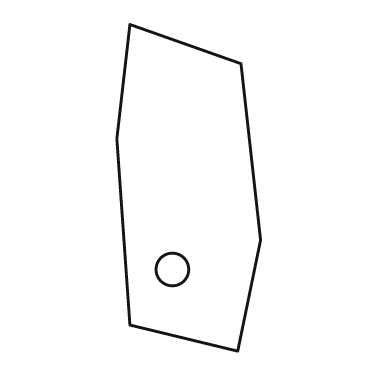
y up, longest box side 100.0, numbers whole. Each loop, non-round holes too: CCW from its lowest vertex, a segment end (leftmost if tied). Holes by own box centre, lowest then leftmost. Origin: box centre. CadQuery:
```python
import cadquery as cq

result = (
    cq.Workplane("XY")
    .moveTo(15.0, -50.0)
    .lineTo(22.0, -16.0)
    .lineTo(16.0, 38.0)
    .lineTo(-18.0, 50.0)
    .lineTo(-22.0, 15.0)
    .lineTo(-18.0, -42.0)
    .close()
    .moveTo(-5.0, -25.0)
    .circle(5.0)
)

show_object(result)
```